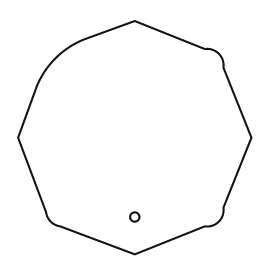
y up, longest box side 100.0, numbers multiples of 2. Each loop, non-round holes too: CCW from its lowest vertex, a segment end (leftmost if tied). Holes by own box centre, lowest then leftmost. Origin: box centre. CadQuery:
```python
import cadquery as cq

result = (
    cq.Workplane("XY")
    .moveTo(0.0, -50.0)
    .lineTo(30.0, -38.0)
    .threePointArc((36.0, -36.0), (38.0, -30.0))
    .lineTo(50.0, 0.0)
    .lineTo(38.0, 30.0)
    .threePointArc((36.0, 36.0), (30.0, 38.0))
    .lineTo(0.0, 50.0)
    .lineTo(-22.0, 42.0)
    .threePointArc((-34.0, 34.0), (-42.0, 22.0))
    .lineTo(-50.0, 0.0)
    .lineTo(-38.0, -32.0)
    .threePointArc((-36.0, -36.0), (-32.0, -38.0))
    .close()
    .moveTo(0.0, -34.0)
    .circle(2.0)
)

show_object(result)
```